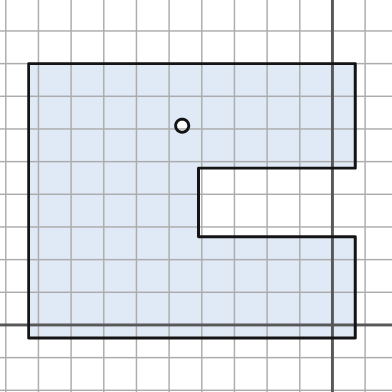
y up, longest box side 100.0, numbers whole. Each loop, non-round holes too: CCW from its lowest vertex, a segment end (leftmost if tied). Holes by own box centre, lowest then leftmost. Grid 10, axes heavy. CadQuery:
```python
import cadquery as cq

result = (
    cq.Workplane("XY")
    .moveTo(-93.0, -4.0)
    .lineTo(7.0, -4.0)
    .lineTo(7.0, 27.0)
    .lineTo(-41.0, 27.0)
    .lineTo(-41.0, 48.0)
    .lineTo(7.0, 48.0)
    .lineTo(7.0, 80.0)
    .lineTo(-93.0, 80.0)
    .close()
    .moveTo(-46.0, 61.0)
    .circle(2.0)
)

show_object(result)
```